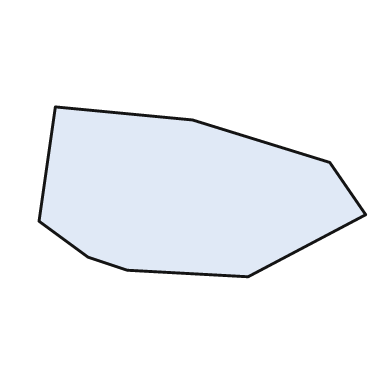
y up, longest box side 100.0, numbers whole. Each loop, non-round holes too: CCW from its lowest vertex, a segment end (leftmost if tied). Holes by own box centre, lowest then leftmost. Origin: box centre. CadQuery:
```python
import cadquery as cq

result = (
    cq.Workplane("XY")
    .moveTo(14.0, -26.0)
    .lineTo(50.0, -7.0)
    .lineTo(39.0, 9.0)
    .lineTo(-3.0, 22.0)
    .lineTo(-45.0, 26.0)
    .lineTo(-50.0, -9.0)
    .lineTo(-35.0, -20.0)
    .lineTo(-23.0, -24.0)
    .close()
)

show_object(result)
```